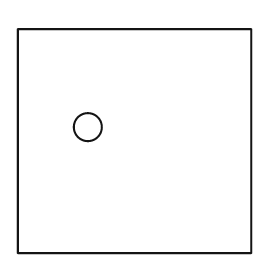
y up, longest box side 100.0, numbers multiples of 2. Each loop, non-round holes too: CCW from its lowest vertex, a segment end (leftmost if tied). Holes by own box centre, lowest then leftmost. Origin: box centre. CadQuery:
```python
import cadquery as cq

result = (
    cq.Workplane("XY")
    .moveTo(-50.0, -48.0)
    .lineTo(50.0, -48.0)
    .lineTo(50.0, 48.0)
    .lineTo(-50.0, 48.0)
    .close()
    .moveTo(-20.0, 6.0)
    .circle(6.0)
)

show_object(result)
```